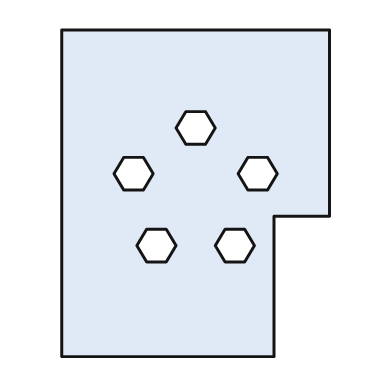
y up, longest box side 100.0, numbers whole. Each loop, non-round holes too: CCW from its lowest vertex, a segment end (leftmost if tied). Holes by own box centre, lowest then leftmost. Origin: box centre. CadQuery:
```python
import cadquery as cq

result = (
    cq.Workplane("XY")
    .moveTo(-41.0, -50.0)
    .lineTo(24.0, -50.0)
    .lineTo(24.0, -7.0)
    .lineTo(41.0, -7.0)
    .lineTo(41.0, 50.0)
    .lineTo(-41.0, 50.0)
    .close()
    .moveTo(-15.0, -21.0)
    .lineTo(-9.0, -21.0)
    .lineTo(-6.0, -16.0)
    .lineTo(-9.0, -11.0)
    .lineTo(-15.0, -11.0)
    .lineTo(-18.0, -16.0)
    .close()
    .moveTo(9.0, -21.0)
    .lineTo(15.0, -21.0)
    .lineTo(18.0, -16.0)
    .lineTo(15.0, -11.0)
    .lineTo(9.0, -11.0)
    .lineTo(6.0, -16.0)
    .close()
    .moveTo(-22.0, 1.0)
    .lineTo(-16.0, 1.0)
    .lineTo(-13.0, 6.0)
    .lineTo(-16.0, 11.0)
    .lineTo(-22.0, 11.0)
    .lineTo(-25.0, 6.0)
    .close()
    .moveTo(16.0, 1.0)
    .lineTo(22.0, 1.0)
    .lineTo(25.0, 6.0)
    .lineTo(22.0, 11.0)
    .lineTo(16.0, 11.0)
    .lineTo(13.0, 6.0)
    .close()
    .moveTo(-3.0, 15.0)
    .lineTo(3.0, 15.0)
    .lineTo(6.0, 20.0)
    .lineTo(3.0, 25.0)
    .lineTo(-3.0, 25.0)
    .lineTo(-6.0, 20.0)
    .close()
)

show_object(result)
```